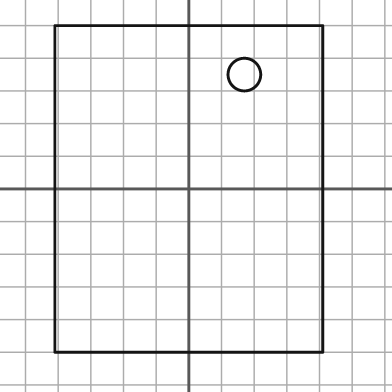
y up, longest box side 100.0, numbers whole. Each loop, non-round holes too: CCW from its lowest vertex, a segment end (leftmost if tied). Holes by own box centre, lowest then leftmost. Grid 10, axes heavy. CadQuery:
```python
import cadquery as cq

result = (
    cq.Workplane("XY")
    .moveTo(-41.0, -50.0)
    .lineTo(41.0, -50.0)
    .lineTo(41.0, 50.0)
    .lineTo(-41.0, 50.0)
    .close()
    .moveTo(17.0, 35.0)
    .circle(5.0)
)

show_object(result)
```